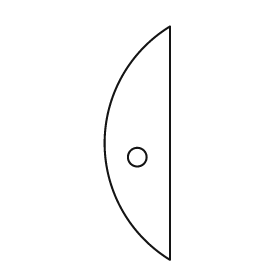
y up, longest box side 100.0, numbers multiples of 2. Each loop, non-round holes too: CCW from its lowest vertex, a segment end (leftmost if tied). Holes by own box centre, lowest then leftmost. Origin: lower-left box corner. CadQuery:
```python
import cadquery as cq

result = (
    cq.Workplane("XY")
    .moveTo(28.0, 0.0)
    .lineTo(28.0, 100.0)
    .threePointArc((0.0, 50.0), (28.0, 0.0))
    .close()
    .moveTo(14.0, 44.0)
    .circle(4.0)
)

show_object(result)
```